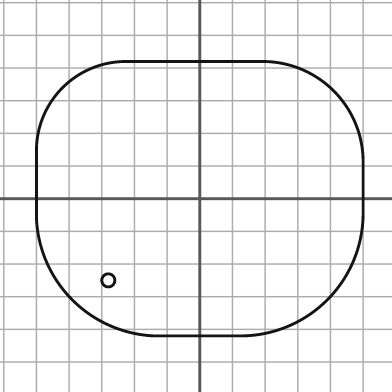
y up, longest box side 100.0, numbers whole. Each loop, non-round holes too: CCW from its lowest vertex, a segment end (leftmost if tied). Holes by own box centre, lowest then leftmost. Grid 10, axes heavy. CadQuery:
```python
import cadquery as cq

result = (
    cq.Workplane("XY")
    .moveTo(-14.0, -42.0)
    .lineTo(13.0, -42.0)
    .threePointArc((39.0, -31.0), (50.0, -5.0))
    .lineTo(50.0, 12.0)
    .threePointArc((41.0, 33.0), (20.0, 42.0))
    .lineTo(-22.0, 42.0)
    .threePointArc((-42.0, 34.0), (-50.0, 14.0))
    .lineTo(-50.0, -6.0)
    .threePointArc((-39.0, -31.0), (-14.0, -42.0))
    .close()
    .moveTo(-28.0, -25.0)
    .circle(2.0)
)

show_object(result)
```